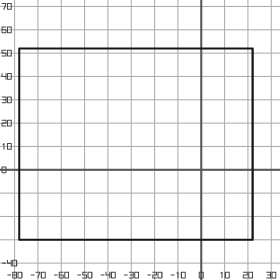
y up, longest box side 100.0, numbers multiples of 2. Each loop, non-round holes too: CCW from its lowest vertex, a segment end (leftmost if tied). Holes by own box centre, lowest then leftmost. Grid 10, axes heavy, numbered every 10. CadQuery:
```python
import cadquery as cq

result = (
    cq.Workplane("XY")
    .moveTo(-78.0, -30.0)
    .lineTo(22.0, -30.0)
    .lineTo(22.0, 52.0)
    .lineTo(-78.0, 52.0)
    .close()
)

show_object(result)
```